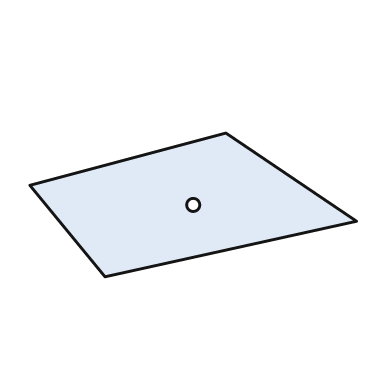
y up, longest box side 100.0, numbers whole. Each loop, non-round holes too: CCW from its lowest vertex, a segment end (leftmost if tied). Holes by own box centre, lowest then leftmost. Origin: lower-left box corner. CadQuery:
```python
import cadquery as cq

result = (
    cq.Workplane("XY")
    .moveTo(23.0, 0.0)
    .lineTo(100.0, 17.0)
    .lineTo(60.0, 44.0)
    .lineTo(0.0, 28.0)
    .close()
    .moveTo(50.0, 22.0)
    .circle(2.0)
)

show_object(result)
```